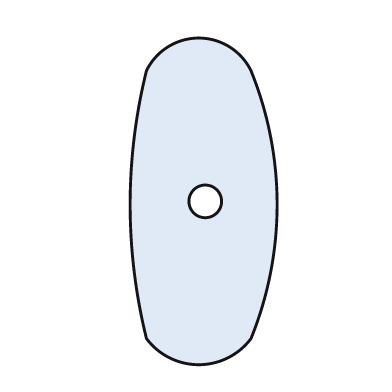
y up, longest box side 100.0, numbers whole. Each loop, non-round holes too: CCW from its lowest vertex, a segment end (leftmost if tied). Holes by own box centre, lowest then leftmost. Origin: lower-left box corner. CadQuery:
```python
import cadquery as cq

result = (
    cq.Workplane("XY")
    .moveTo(5.0, 8.0)
    .threePointArc((21.0, 0.0), (37.0, 8.0))
    .threePointArc((45.0, 49.0), (37.0, 90.0))
    .threePointArc((21.0, 100.0), (5.0, 90.0))
    .threePointArc((0.0, 49.0), (5.0, 8.0))
    .close()
    .moveTo(23.0, 50.0)
    .circle(5.0)
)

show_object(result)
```